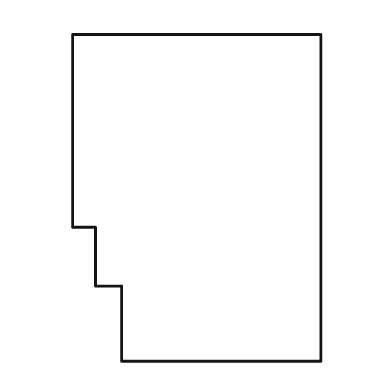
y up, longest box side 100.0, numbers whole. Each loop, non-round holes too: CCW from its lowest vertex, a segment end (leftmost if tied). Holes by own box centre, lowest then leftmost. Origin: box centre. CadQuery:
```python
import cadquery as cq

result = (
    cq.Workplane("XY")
    .moveTo(-23.0, -50.0)
    .lineTo(38.0, -50.0)
    .lineTo(38.0, 50.0)
    .lineTo(-38.0, 50.0)
    .lineTo(-38.0, -9.0)
    .lineTo(-31.0, -9.0)
    .lineTo(-31.0, -27.0)
    .lineTo(-23.0, -27.0)
    .close()
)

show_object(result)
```